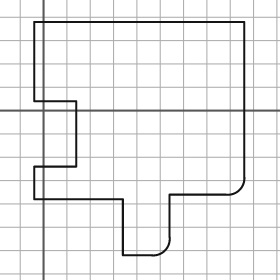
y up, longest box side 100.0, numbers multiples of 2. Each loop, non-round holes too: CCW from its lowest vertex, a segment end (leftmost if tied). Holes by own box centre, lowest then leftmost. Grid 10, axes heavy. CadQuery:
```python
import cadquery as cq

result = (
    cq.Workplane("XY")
    .moveTo(34.0, -62.0)
    .lineTo(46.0, -62.0)
    .threePointArc((52.0, -60.0), (54.0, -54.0))
    .lineTo(54.0, -36.0)
    .lineTo(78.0, -36.0)
    .threePointArc((84.0, -34.0), (86.0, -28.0))
    .lineTo(86.0, 38.0)
    .lineTo(-4.0, 38.0)
    .lineTo(-4.0, 4.0)
    .lineTo(14.0, 4.0)
    .lineTo(14.0, -24.0)
    .lineTo(-4.0, -24.0)
    .lineTo(-4.0, -38.0)
    .lineTo(34.0, -38.0)
    .close()
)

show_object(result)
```